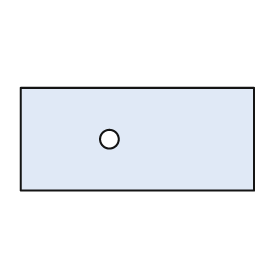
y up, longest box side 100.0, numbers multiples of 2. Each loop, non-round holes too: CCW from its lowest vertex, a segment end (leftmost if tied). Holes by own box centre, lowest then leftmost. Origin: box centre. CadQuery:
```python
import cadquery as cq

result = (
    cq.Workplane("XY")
    .moveTo(-50.0, -22.0)
    .lineTo(50.0, -22.0)
    .lineTo(50.0, 22.0)
    .lineTo(-50.0, 22.0)
    .close()
    .moveTo(-12.0, 0.0)
    .circle(4.0)
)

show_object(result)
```